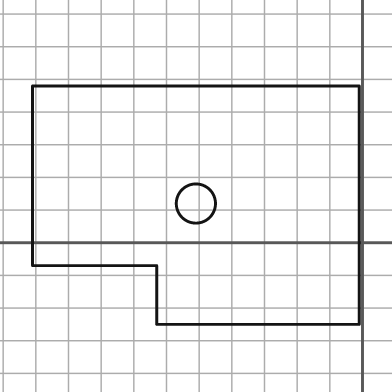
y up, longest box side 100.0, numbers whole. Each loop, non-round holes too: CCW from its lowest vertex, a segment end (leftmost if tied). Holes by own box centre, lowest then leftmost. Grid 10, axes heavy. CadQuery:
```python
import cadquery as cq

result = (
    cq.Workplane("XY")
    .moveTo(-63.0, -25.0)
    .lineTo(-1.0, -25.0)
    .lineTo(-1.0, 48.0)
    .lineTo(-101.0, 48.0)
    .lineTo(-101.0, -7.0)
    .lineTo(-63.0, -7.0)
    .close()
    .moveTo(-51.0, 12.0)
    .circle(6.0)
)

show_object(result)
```